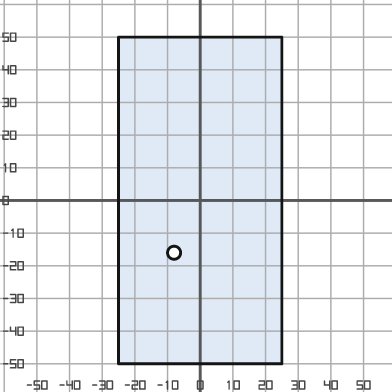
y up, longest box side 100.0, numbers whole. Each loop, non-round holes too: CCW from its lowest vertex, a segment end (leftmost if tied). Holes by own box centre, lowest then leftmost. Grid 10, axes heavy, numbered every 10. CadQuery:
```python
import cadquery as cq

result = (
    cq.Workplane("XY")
    .moveTo(-25.0, -50.0)
    .lineTo(25.0, -50.0)
    .lineTo(25.0, 50.0)
    .lineTo(-25.0, 50.0)
    .close()
    .moveTo(-8.0, -16.0)
    .circle(2.0)
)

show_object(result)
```